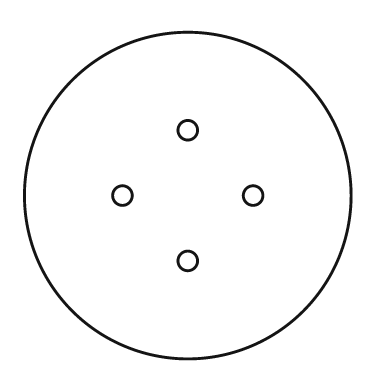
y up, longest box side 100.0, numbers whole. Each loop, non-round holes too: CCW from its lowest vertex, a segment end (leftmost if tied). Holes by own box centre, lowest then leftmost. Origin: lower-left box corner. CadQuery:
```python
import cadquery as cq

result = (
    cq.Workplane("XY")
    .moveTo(50.0, 50.0)
    .circle(50.0)
    .moveTo(50.0, 30.0)
    .circle(3.0)
    .moveTo(30.0, 50.0)
    .circle(3.0)
    .moveTo(70.0, 50.0)
    .circle(3.0)
    .moveTo(50.0, 70.0)
    .circle(3.0)
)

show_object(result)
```